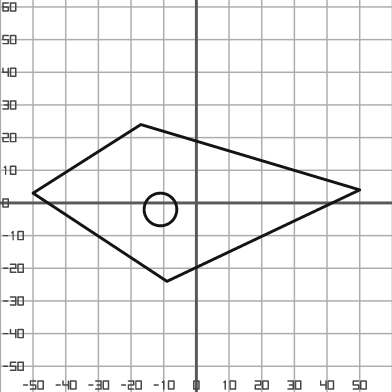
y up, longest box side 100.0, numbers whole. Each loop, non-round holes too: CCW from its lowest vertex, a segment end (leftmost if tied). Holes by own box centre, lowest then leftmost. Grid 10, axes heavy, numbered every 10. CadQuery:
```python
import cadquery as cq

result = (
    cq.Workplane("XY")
    .moveTo(-9.0, -24.0)
    .lineTo(50.0, 4.0)
    .lineTo(-17.0, 24.0)
    .lineTo(-50.0, 3.0)
    .close()
    .moveTo(-11.0, -2.0)
    .circle(5.0)
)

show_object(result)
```